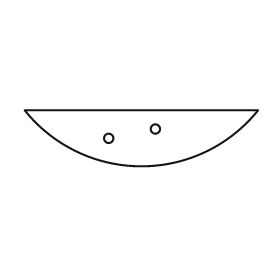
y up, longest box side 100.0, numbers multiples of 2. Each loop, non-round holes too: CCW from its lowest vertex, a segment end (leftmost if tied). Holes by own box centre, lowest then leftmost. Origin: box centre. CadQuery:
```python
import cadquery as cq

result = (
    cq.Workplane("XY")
    .moveTo(-50.0, 12.0)
    .threePointArc((0.0, -12.0), (50.0, 12.0))
    .close()
    .moveTo(-14.0, 0.0)
    .circle(2.0)
    .moveTo(6.0, 4.0)
    .circle(2.0)
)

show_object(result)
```